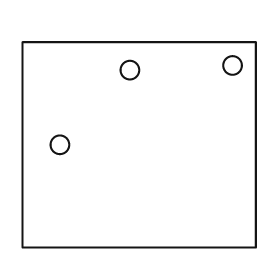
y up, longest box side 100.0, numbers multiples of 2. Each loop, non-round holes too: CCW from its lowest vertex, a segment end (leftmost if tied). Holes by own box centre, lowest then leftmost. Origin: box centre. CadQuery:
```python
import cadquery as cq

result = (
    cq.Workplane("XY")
    .moveTo(-50.0, -44.0)
    .lineTo(50.0, -44.0)
    .lineTo(50.0, 44.0)
    .lineTo(-50.0, 44.0)
    .close()
    .moveTo(-34.0, 0.0)
    .circle(4.0)
    .moveTo(-4.0, 32.0)
    .circle(4.0)
    .moveTo(40.0, 34.0)
    .circle(4.0)
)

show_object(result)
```